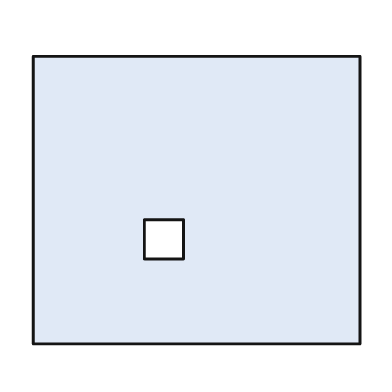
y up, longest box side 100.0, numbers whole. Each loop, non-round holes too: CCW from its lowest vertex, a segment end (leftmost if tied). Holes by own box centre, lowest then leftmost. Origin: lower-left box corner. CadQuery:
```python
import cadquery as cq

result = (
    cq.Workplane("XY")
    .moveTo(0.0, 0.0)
    .lineTo(100.0, 0.0)
    .lineTo(100.0, 88.0)
    .lineTo(0.0, 88.0)
    .close()
    .moveTo(34.0, 26.0)
    .lineTo(46.0, 26.0)
    .lineTo(46.0, 38.0)
    .lineTo(34.0, 38.0)
    .close()
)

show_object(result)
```